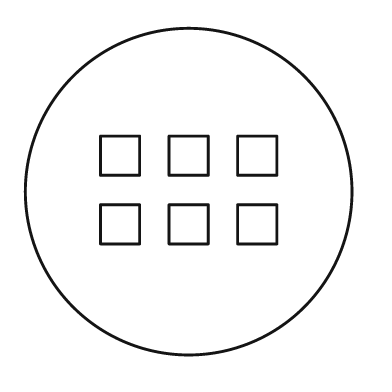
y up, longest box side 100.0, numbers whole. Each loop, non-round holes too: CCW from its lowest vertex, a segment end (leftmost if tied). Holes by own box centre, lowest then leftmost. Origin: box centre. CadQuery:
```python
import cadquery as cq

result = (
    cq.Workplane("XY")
    .moveTo(0.0, 0.0)
    .circle(50.0)
    .moveTo(-27.0, -16.0)
    .lineTo(-15.0, -16.0)
    .lineTo(-15.0, -4.0)
    .lineTo(-27.0, -4.0)
    .close()
    .moveTo(-6.0, -16.0)
    .lineTo(6.0, -16.0)
    .lineTo(6.0, -4.0)
    .lineTo(-6.0, -4.0)
    .close()
    .moveTo(15.0, -16.0)
    .lineTo(27.0, -16.0)
    .lineTo(27.0, -4.0)
    .lineTo(15.0, -4.0)
    .close()
    .moveTo(-27.0, 5.0)
    .lineTo(-15.0, 5.0)
    .lineTo(-15.0, 17.0)
    .lineTo(-27.0, 17.0)
    .close()
    .moveTo(-6.0, 5.0)
    .lineTo(6.0, 5.0)
    .lineTo(6.0, 17.0)
    .lineTo(-6.0, 17.0)
    .close()
    .moveTo(15.0, 5.0)
    .lineTo(27.0, 5.0)
    .lineTo(27.0, 17.0)
    .lineTo(15.0, 17.0)
    .close()
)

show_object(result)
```